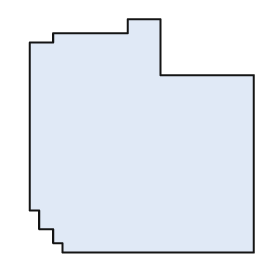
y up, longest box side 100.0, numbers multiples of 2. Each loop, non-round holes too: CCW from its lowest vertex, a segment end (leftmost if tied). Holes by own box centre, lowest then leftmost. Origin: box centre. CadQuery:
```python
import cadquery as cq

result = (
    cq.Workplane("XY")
    .moveTo(-34.0, -50.0)
    .lineTo(48.0, -50.0)
    .lineTo(48.0, 26.0)
    .lineTo(8.0, 26.0)
    .lineTo(8.0, 50.0)
    .lineTo(-6.0, 50.0)
    .lineTo(-6.0, 44.0)
    .lineTo(-38.0, 44.0)
    .lineTo(-38.0, 40.0)
    .lineTo(-48.0, 40.0)
    .lineTo(-48.0, -32.0)
    .lineTo(-44.0, -32.0)
    .lineTo(-44.0, -40.0)
    .lineTo(-38.0, -40.0)
    .lineTo(-38.0, -46.0)
    .lineTo(-34.0, -46.0)
    .close()
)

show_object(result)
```